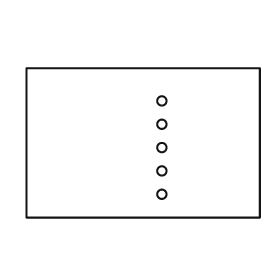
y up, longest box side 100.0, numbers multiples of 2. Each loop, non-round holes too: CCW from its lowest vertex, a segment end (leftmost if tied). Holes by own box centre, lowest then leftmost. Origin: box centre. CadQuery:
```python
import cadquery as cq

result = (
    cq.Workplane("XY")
    .moveTo(-50.0, -32.0)
    .lineTo(50.0, -32.0)
    .lineTo(50.0, 32.0)
    .lineTo(-50.0, 32.0)
    .close()
    .moveTo(8.0, -22.0)
    .circle(2.0)
    .moveTo(8.0, -12.0)
    .circle(2.0)
    .moveTo(8.0, -2.0)
    .circle(2.0)
    .moveTo(8.0, 8.0)
    .circle(2.0)
    .moveTo(8.0, 18.0)
    .circle(2.0)
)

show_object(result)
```